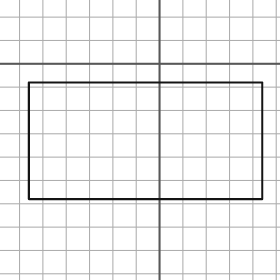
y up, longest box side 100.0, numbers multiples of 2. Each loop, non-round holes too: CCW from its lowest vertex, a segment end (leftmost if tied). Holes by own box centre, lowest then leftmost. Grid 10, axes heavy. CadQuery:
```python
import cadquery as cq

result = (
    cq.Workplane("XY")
    .moveTo(-56.0, -58.0)
    .lineTo(44.0, -58.0)
    .lineTo(44.0, -8.0)
    .lineTo(-56.0, -8.0)
    .close()
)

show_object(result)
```